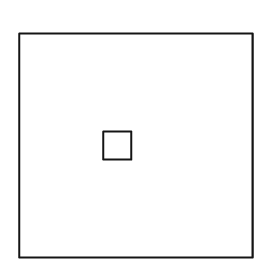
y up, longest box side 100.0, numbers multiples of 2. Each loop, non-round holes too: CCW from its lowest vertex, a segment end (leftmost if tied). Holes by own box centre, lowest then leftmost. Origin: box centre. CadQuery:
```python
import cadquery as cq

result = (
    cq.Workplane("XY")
    .moveTo(-50.0, -48.0)
    .lineTo(50.0, -48.0)
    .lineTo(50.0, 48.0)
    .lineTo(-50.0, 48.0)
    .close()
    .moveTo(-14.0, -6.0)
    .lineTo(-2.0, -6.0)
    .lineTo(-2.0, 6.0)
    .lineTo(-14.0, 6.0)
    .close()
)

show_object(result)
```